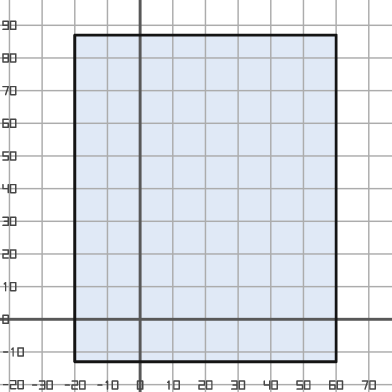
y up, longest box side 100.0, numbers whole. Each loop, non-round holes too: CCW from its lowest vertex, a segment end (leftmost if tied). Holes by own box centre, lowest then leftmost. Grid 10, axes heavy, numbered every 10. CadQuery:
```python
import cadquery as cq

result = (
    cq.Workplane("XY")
    .moveTo(-20.0, -13.0)
    .lineTo(60.0, -13.0)
    .lineTo(60.0, 87.0)
    .lineTo(-20.0, 87.0)
    .close()
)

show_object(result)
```